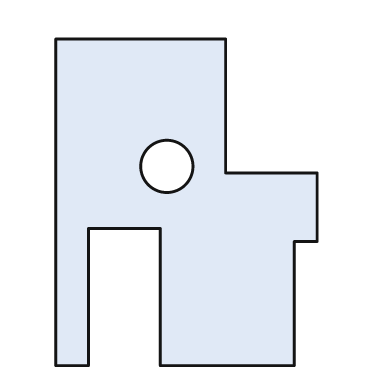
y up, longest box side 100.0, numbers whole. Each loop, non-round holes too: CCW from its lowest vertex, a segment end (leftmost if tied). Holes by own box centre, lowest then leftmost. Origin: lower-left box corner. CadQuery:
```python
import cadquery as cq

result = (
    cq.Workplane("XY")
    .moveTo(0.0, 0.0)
    .lineTo(10.0, 0.0)
    .lineTo(10.0, 42.0)
    .lineTo(32.0, 42.0)
    .lineTo(32.0, 0.0)
    .lineTo(73.0, 0.0)
    .lineTo(73.0, 38.0)
    .lineTo(80.0, 38.0)
    .lineTo(80.0, 59.0)
    .lineTo(52.0, 59.0)
    .lineTo(52.0, 100.0)
    .lineTo(0.0, 100.0)
    .close()
    .moveTo(34.0, 61.0)
    .circle(8.0)
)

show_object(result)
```